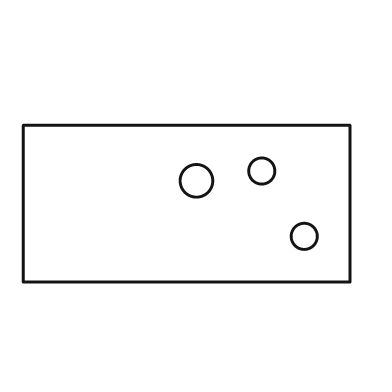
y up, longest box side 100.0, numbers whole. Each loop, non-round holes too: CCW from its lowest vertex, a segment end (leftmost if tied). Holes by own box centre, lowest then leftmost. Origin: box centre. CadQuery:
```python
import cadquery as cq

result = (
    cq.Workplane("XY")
    .moveTo(-50.0, -24.0)
    .lineTo(50.0, -24.0)
    .lineTo(50.0, 24.0)
    .lineTo(-50.0, 24.0)
    .close()
    .moveTo(36.0, -10.0)
    .circle(4.0)
    .moveTo(3.0, 7.0)
    .circle(5.0)
    .moveTo(23.0, 10.0)
    .circle(4.0)
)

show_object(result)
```